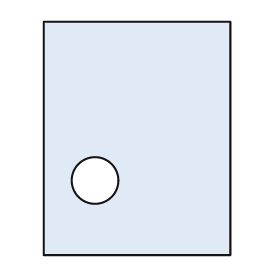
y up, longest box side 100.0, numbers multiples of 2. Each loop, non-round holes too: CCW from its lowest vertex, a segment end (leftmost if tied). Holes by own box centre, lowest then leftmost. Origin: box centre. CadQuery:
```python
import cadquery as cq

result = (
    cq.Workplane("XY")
    .moveTo(-40.0, -50.0)
    .lineTo(40.0, -50.0)
    .lineTo(40.0, 50.0)
    .lineTo(-40.0, 50.0)
    .close()
    .moveTo(-18.0, -18.0)
    .circle(10.0)
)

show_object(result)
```